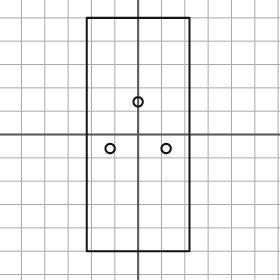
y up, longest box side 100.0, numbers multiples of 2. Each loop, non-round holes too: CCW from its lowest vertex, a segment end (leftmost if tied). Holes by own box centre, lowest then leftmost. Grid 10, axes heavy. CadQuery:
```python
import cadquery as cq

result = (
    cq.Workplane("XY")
    .moveTo(-22.0, -50.0)
    .lineTo(22.0, -50.0)
    .lineTo(22.0, 50.0)
    .lineTo(-22.0, 50.0)
    .close()
    .moveTo(-12.0, -6.0)
    .circle(2.0)
    .moveTo(12.0, -6.0)
    .circle(2.0)
    .moveTo(0.0, 14.0)
    .circle(2.0)
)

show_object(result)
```